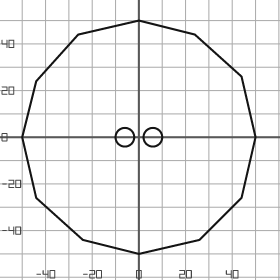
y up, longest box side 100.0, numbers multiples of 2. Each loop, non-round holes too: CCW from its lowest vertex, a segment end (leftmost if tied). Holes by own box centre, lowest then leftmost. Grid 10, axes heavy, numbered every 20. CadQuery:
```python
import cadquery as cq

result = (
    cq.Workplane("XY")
    .moveTo(0.0, -50.0)
    .lineTo(26.0, -44.0)
    .lineTo(44.0, -26.0)
    .lineTo(50.0, 0.0)
    .lineTo(44.0, 26.0)
    .lineTo(24.0, 44.0)
    .lineTo(0.0, 50.0)
    .lineTo(-26.0, 44.0)
    .lineTo(-44.0, 24.0)
    .lineTo(-50.0, 0.0)
    .lineTo(-44.0, -26.0)
    .lineTo(-24.0, -44.0)
    .close()
    .moveTo(-6.0, 0.0)
    .circle(4.0)
    .moveTo(6.0, 0.0)
    .circle(4.0)
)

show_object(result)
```